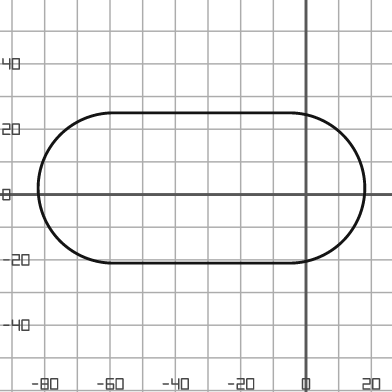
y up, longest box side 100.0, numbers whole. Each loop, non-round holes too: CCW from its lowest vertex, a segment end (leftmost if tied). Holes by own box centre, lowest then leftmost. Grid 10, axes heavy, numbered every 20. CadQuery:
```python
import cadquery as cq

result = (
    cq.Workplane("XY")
    .moveTo(-59.0, -21.0)
    .lineTo(-5.0, -21.0)
    .threePointArc((18.0, 2.0), (-5.0, 25.0))
    .lineTo(-59.0, 25.0)
    .threePointArc((-82.0, 2.0), (-59.0, -21.0))
    .close()
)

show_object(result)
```